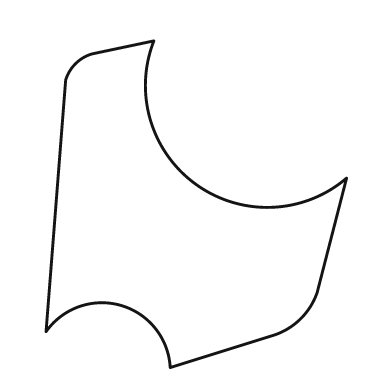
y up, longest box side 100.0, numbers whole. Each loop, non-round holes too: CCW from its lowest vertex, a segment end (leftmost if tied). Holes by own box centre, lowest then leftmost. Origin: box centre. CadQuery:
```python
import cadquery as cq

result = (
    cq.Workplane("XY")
    .moveTo(-8.0, -50.0)
    .lineTo(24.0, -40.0)
    .threePointArc((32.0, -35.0), (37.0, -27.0))
    .lineTo(46.0, 8.0)
    .threePointArc((0.0, 6.0), (-13.0, 50.0))
    .lineTo(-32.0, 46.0)
    .threePointArc((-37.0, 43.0), (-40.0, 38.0))
    .lineTo(-46.0, -39.0)
    .threePointArc((-23.0, -31.0), (-8.0, -50.0))
    .close()
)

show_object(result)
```